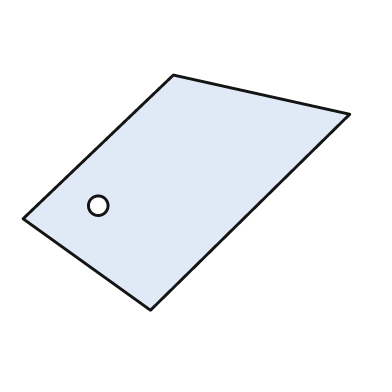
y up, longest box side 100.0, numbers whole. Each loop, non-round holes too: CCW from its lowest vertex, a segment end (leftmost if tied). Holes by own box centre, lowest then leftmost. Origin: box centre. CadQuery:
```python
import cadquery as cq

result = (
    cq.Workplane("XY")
    .moveTo(-11.0, -36.0)
    .lineTo(50.0, 24.0)
    .lineTo(-4.0, 36.0)
    .lineTo(-50.0, -8.0)
    .close()
    .moveTo(-27.0, -4.0)
    .circle(3.0)
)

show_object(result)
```